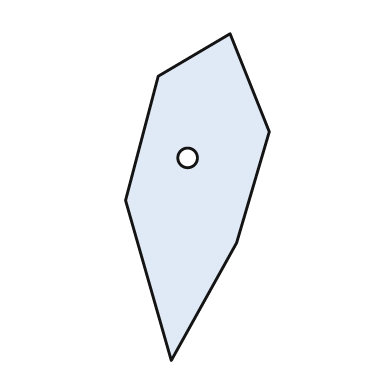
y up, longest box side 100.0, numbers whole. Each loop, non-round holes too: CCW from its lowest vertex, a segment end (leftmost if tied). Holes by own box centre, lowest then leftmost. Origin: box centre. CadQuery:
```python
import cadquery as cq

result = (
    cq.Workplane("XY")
    .moveTo(-8.0, -50.0)
    .lineTo(12.0, -14.0)
    .lineTo(22.0, 20.0)
    .lineTo(10.0, 50.0)
    .lineTo(-12.0, 37.0)
    .lineTo(-22.0, -1.0)
    .close()
    .moveTo(-3.0, 12.0)
    .circle(3.0)
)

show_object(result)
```